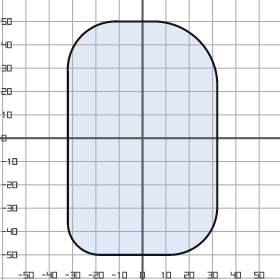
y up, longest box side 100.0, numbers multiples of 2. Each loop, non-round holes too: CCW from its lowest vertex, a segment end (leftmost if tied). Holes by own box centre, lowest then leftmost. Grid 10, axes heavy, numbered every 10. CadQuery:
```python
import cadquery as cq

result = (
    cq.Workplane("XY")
    .moveTo(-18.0, -50.0)
    .lineTo(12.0, -50.0)
    .threePointArc((26.0, -44.0), (32.0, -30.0))
    .lineTo(32.0, 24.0)
    .threePointArc((24.0, 42.0), (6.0, 50.0))
    .lineTo(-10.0, 50.0)
    .threePointArc((-26.0, 44.0), (-32.0, 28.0))
    .lineTo(-32.0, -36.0)
    .threePointArc((-28.0, -46.0), (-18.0, -50.0))
    .close()
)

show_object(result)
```